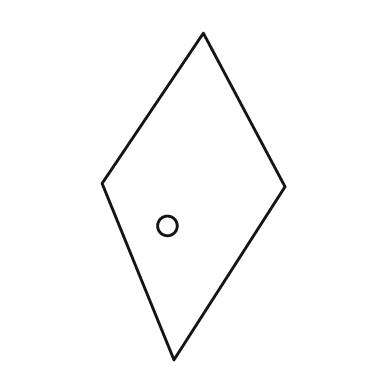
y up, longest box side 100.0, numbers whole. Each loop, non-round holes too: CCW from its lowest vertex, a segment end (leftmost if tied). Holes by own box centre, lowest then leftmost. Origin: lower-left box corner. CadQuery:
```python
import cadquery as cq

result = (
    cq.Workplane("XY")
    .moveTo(22.0, 0.0)
    .lineTo(56.0, 53.0)
    .lineTo(31.0, 100.0)
    .lineTo(0.0, 54.0)
    .close()
    .moveTo(20.0, 41.0)
    .circle(3.0)
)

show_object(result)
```